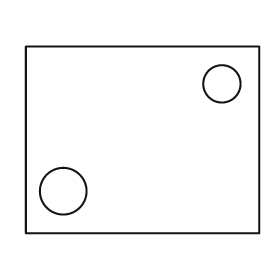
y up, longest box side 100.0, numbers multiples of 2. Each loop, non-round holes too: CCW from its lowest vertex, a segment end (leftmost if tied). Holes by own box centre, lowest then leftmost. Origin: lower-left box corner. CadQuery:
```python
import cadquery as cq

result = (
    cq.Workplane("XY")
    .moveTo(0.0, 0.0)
    .lineTo(100.0, 0.0)
    .lineTo(100.0, 80.0)
    .lineTo(0.0, 80.0)
    .close()
    .moveTo(16.0, 18.0)
    .circle(10.0)
    .moveTo(84.0, 64.0)
    .circle(8.0)
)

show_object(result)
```